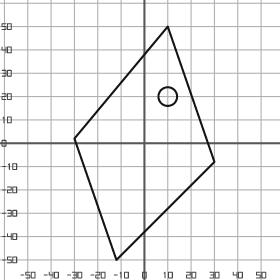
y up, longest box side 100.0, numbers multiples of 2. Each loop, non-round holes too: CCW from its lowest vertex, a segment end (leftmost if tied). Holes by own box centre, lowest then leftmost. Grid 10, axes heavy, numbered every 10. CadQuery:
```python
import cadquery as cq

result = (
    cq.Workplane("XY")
    .moveTo(-12.0, -50.0)
    .lineTo(30.0, -8.0)
    .lineTo(10.0, 50.0)
    .lineTo(-30.0, 2.0)
    .close()
    .moveTo(10.0, 20.0)
    .circle(4.0)
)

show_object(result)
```